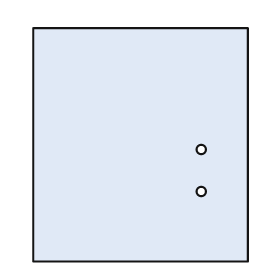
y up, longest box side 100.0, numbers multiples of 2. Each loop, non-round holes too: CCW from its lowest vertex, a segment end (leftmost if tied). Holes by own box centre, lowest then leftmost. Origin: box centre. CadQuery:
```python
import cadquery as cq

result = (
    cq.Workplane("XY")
    .moveTo(-46.0, -50.0)
    .lineTo(46.0, -50.0)
    .lineTo(46.0, 50.0)
    .lineTo(-46.0, 50.0)
    .close()
    .moveTo(26.0, -20.0)
    .circle(2.0)
    .moveTo(26.0, -2.0)
    .circle(2.0)
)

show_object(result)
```